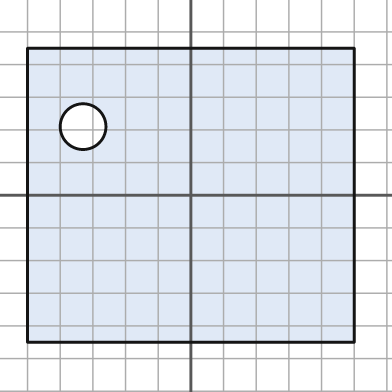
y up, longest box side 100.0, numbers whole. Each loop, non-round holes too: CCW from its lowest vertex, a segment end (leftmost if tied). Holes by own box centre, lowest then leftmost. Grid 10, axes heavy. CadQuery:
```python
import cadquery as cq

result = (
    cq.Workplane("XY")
    .moveTo(-50.0, -45.0)
    .lineTo(50.0, -45.0)
    .lineTo(50.0, 45.0)
    .lineTo(-50.0, 45.0)
    .close()
    .moveTo(-33.0, 21.0)
    .circle(7.0)
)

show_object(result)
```